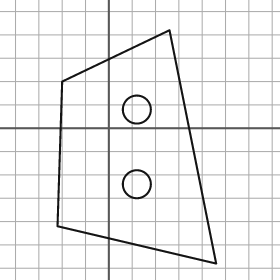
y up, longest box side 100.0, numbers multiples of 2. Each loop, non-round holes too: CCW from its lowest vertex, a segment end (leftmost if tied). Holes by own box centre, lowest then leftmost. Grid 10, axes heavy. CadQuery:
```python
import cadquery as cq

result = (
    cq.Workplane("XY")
    .moveTo(46.0, -58.0)
    .lineTo(26.0, 42.0)
    .lineTo(-20.0, 20.0)
    .lineTo(-22.0, -42.0)
    .close()
    .moveTo(12.0, -24.0)
    .circle(6.0)
    .moveTo(12.0, 8.0)
    .circle(6.0)
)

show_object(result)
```